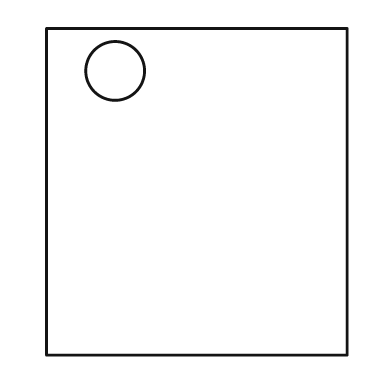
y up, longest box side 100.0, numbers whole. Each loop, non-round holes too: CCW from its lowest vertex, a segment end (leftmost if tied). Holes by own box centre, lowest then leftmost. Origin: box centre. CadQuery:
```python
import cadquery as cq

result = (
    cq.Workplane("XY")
    .moveTo(-46.0, -50.0)
    .lineTo(46.0, -50.0)
    .lineTo(46.0, 50.0)
    .lineTo(-46.0, 50.0)
    .close()
    .moveTo(-25.0, 37.0)
    .circle(9.0)
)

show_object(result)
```